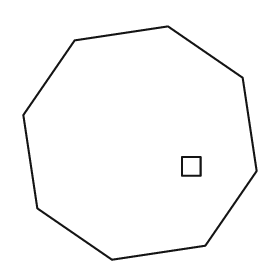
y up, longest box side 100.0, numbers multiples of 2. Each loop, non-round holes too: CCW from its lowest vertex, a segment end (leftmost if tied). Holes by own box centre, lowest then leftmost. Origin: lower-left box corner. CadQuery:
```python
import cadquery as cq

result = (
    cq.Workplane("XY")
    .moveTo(38.0, 0.0)
    .lineTo(78.0, 6.0)
    .lineTo(100.0, 38.0)
    .lineTo(94.0, 78.0)
    .lineTo(62.0, 100.0)
    .lineTo(22.0, 94.0)
    .lineTo(0.0, 62.0)
    .lineTo(6.0, 22.0)
    .close()
    .moveTo(68.0, 36.0)
    .lineTo(76.0, 36.0)
    .lineTo(76.0, 44.0)
    .lineTo(68.0, 44.0)
    .close()
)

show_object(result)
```